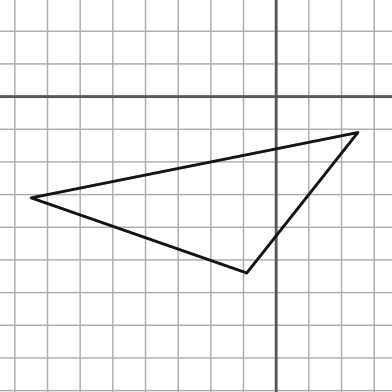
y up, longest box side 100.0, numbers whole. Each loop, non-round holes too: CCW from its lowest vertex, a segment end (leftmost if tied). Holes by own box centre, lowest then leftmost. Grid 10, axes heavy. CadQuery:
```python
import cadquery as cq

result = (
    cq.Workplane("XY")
    .moveTo(-9.0, -54.0)
    .lineTo(25.0, -11.0)
    .lineTo(-75.0, -31.0)
    .close()
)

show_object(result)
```